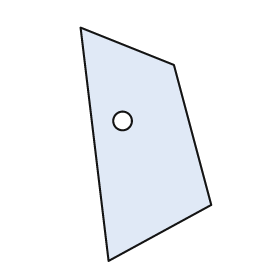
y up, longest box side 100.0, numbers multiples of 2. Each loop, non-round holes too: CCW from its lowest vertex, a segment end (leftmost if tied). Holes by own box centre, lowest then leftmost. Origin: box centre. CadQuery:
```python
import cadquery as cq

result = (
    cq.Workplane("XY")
    .moveTo(-16.0, -50.0)
    .lineTo(28.0, -26.0)
    .lineTo(12.0, 34.0)
    .lineTo(-28.0, 50.0)
    .close()
    .moveTo(-10.0, 10.0)
    .circle(4.0)
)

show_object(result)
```